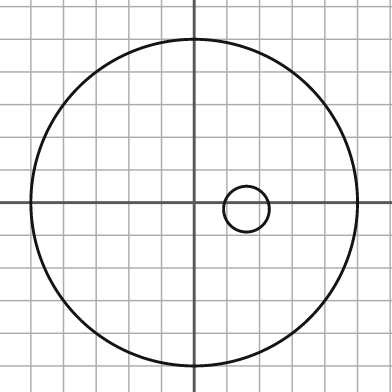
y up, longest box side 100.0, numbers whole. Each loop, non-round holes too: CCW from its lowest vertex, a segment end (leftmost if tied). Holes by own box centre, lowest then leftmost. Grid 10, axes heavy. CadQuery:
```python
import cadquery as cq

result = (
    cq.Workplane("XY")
    .moveTo(0.0, 0.0)
    .circle(50.0)
    .moveTo(16.0, -2.0)
    .circle(7.0)
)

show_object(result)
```